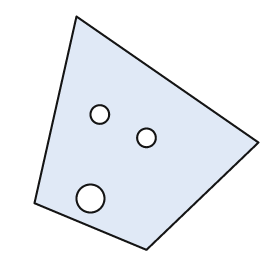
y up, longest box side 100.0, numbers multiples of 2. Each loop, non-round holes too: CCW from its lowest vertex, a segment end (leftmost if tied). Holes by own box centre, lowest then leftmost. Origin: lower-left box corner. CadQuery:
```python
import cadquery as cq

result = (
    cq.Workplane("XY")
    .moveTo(48.0, 0.0)
    .lineTo(96.0, 46.0)
    .lineTo(18.0, 100.0)
    .lineTo(0.0, 20.0)
    .close()
    .moveTo(24.0, 22.0)
    .circle(6.0)
    .moveTo(48.0, 48.0)
    .circle(4.0)
    .moveTo(28.0, 58.0)
    .circle(4.0)
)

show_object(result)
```